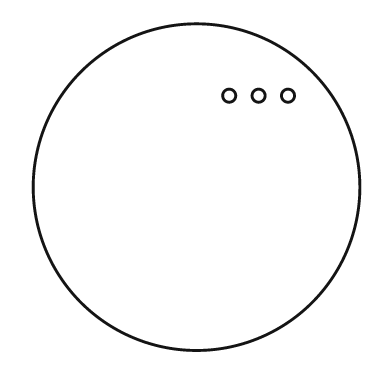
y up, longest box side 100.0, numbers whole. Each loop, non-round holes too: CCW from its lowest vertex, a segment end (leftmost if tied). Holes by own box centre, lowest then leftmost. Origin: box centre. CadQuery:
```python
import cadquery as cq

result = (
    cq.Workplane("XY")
    .moveTo(0.0, 0.0)
    .circle(50.0)
    .moveTo(10.0, 28.0)
    .circle(2.0)
    .moveTo(19.0, 28.0)
    .circle(2.0)
    .moveTo(28.0, 28.0)
    .circle(2.0)
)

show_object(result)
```